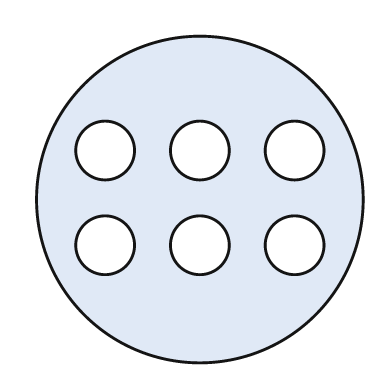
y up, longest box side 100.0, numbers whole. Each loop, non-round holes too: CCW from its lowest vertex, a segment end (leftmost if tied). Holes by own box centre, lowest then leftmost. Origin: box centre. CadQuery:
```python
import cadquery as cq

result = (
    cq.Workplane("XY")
    .moveTo(0.0, 0.0)
    .circle(50.0)
    .moveTo(-29.0, -14.0)
    .circle(9.0)
    .moveTo(0.0, -14.0)
    .circle(9.0)
    .moveTo(29.0, -14.0)
    .circle(9.0)
    .moveTo(-29.0, 15.0)
    .circle(9.0)
    .moveTo(0.0, 15.0)
    .circle(9.0)
    .moveTo(29.0, 15.0)
    .circle(9.0)
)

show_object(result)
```